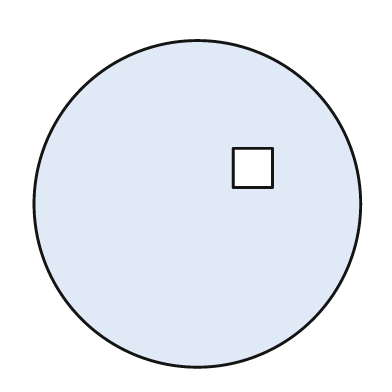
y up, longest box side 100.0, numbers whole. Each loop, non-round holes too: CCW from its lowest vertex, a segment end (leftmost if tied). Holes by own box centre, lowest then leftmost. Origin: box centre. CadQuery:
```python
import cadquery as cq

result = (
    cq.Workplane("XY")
    .moveTo(0.0, 0.0)
    .circle(50.0)
    .moveTo(11.0, 5.0)
    .lineTo(23.0, 5.0)
    .lineTo(23.0, 17.0)
    .lineTo(11.0, 17.0)
    .close()
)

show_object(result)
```